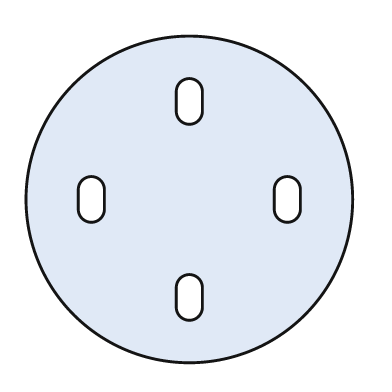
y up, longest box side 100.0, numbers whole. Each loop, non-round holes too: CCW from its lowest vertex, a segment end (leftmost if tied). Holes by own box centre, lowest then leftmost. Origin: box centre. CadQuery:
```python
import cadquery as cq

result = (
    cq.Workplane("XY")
    .moveTo(0.0, 0.0)
    .circle(50.0)
    .moveTo(-4.0, -33.0)
    .threePointArc((0.0, -37.0), (4.0, -33.0))
    .lineTo(4.0, -27.0)
    .threePointArc((0.0, -23.0), (-4.0, -27.0))
    .close()
    .moveTo(-34.0, -3.0)
    .threePointArc((-30.0, -7.0), (-26.0, -3.0))
    .lineTo(-26.0, 3.0)
    .threePointArc((-30.0, 7.0), (-34.0, 3.0))
    .close()
    .moveTo(26.0, -3.0)
    .threePointArc((30.0, -7.0), (34.0, -3.0))
    .lineTo(34.0, 3.0)
    .threePointArc((30.0, 7.0), (26.0, 3.0))
    .close()
    .moveTo(-4.0, 27.0)
    .threePointArc((0.0, 23.0), (4.0, 27.0))
    .lineTo(4.0, 33.0)
    .threePointArc((0.0, 37.0), (-4.0, 33.0))
    .close()
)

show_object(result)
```